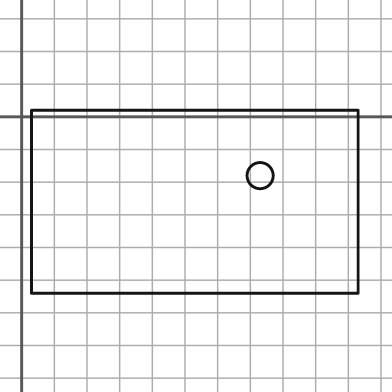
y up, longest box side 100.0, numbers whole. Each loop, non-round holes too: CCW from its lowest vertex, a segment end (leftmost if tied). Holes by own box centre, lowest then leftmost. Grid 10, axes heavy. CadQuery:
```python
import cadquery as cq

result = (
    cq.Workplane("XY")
    .moveTo(3.0, -54.0)
    .lineTo(103.0, -54.0)
    .lineTo(103.0, 2.0)
    .lineTo(3.0, 2.0)
    .close()
    .moveTo(73.0, -18.0)
    .circle(4.0)
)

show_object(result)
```